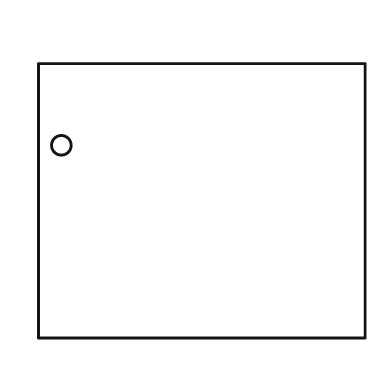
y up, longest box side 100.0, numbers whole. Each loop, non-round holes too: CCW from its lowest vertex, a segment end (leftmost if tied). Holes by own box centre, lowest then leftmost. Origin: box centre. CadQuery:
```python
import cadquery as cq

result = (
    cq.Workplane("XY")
    .moveTo(-50.0, -42.0)
    .lineTo(50.0, -42.0)
    .lineTo(50.0, 42.0)
    .lineTo(-50.0, 42.0)
    .close()
    .moveTo(-43.0, 17.0)
    .circle(3.0)
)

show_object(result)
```